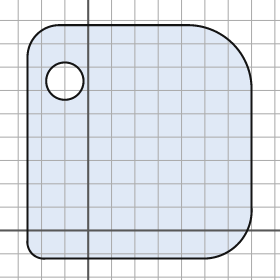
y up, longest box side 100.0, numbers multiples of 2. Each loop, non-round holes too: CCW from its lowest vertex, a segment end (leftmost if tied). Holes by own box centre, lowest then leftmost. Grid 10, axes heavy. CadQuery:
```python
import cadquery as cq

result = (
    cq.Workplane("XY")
    .moveTo(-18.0, -12.0)
    .lineTo(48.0, -12.0)
    .threePointArc((64.0, -6.0), (70.0, 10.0))
    .lineTo(70.0, 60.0)
    .threePointArc((62.0, 80.0), (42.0, 88.0))
    .lineTo(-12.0, 88.0)
    .threePointArc((-22.0, 84.0), (-26.0, 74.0))
    .lineTo(-26.0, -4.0)
    .threePointArc((-24.0, -10.0), (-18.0, -12.0))
    .close()
    .moveTo(-10.0, 64.0)
    .circle(8.0)
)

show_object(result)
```